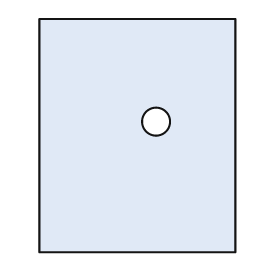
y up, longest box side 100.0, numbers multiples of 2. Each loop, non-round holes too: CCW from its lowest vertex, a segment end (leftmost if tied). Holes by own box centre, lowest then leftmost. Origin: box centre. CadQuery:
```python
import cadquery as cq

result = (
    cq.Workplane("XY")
    .moveTo(-42.0, -50.0)
    .lineTo(42.0, -50.0)
    .lineTo(42.0, 50.0)
    .lineTo(-42.0, 50.0)
    .close()
    .moveTo(8.0, 6.0)
    .circle(6.0)
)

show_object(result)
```